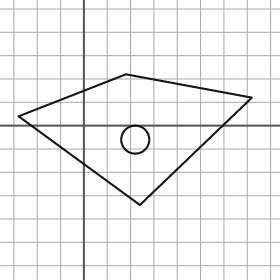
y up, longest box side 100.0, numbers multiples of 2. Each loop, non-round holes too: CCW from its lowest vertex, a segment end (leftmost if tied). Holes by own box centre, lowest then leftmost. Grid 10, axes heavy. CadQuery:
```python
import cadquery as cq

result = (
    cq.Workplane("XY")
    .moveTo(24.0, -34.0)
    .lineTo(72.0, 12.0)
    .lineTo(18.0, 22.0)
    .lineTo(-28.0, 4.0)
    .close()
    .moveTo(22.0, -6.0)
    .circle(6.0)
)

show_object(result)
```